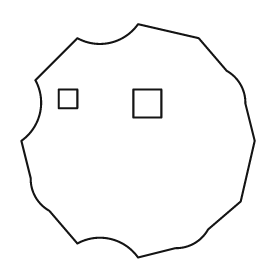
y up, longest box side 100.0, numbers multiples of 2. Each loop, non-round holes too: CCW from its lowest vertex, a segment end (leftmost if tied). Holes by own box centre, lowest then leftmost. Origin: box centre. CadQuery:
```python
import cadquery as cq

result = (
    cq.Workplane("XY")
    .moveTo(0.0, -50.0)
    .lineTo(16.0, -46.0)
    .threePointArc((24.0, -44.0), (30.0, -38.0))
    .lineTo(44.0, -26.0)
    .lineTo(50.0, 0.0)
    .lineTo(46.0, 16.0)
    .threePointArc((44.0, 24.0), (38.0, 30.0))
    .lineTo(26.0, 44.0)
    .lineTo(0.0, 50.0)
    .threePointArc((-12.0, 42.0), (-26.0, 44.0))
    .lineTo(-44.0, 26.0)
    .threePointArc((-42.0, 12.0), (-50.0, 0.0))
    .lineTo(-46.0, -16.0)
    .threePointArc((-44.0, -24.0), (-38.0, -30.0))
    .lineTo(-26.0, -44.0)
    .threePointArc((-12.0, -42.0), (0.0, -50.0))
    .close()
    .moveTo(-2.0, 10.0)
    .lineTo(10.0, 10.0)
    .lineTo(10.0, 22.0)
    .lineTo(-2.0, 22.0)
    .close()
    .moveTo(-34.0, 14.0)
    .lineTo(-26.0, 14.0)
    .lineTo(-26.0, 22.0)
    .lineTo(-34.0, 22.0)
    .close()
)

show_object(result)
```